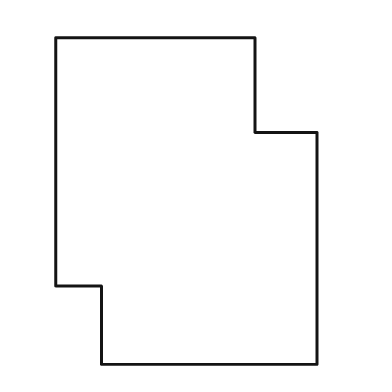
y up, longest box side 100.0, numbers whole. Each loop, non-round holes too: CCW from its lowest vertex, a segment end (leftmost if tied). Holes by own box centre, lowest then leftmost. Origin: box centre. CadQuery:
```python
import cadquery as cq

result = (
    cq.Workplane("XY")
    .moveTo(-26.0, -50.0)
    .lineTo(40.0, -50.0)
    .lineTo(40.0, 21.0)
    .lineTo(21.0, 21.0)
    .lineTo(21.0, 50.0)
    .lineTo(-40.0, 50.0)
    .lineTo(-40.0, -26.0)
    .lineTo(-26.0, -26.0)
    .close()
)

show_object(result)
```